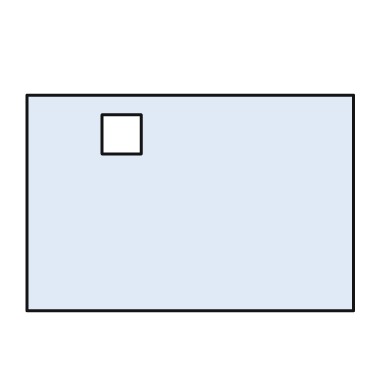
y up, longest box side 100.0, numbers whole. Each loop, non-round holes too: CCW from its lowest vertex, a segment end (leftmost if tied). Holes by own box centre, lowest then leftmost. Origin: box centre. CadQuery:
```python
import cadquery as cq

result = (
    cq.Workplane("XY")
    .moveTo(-50.0, -33.0)
    .lineTo(50.0, -33.0)
    .lineTo(50.0, 33.0)
    .lineTo(-50.0, 33.0)
    .close()
    .moveTo(-27.0, 15.0)
    .lineTo(-15.0, 15.0)
    .lineTo(-15.0, 27.0)
    .lineTo(-27.0, 27.0)
    .close()
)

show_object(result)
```